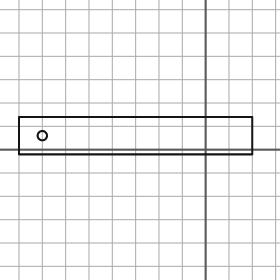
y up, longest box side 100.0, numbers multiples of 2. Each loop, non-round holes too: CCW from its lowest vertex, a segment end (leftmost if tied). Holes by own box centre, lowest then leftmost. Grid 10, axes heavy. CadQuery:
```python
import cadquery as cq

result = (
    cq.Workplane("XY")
    .moveTo(-80.0, -2.0)
    .lineTo(20.0, -2.0)
    .lineTo(20.0, 14.0)
    .lineTo(-80.0, 14.0)
    .close()
    .moveTo(-70.0, 6.0)
    .circle(2.0)
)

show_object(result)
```